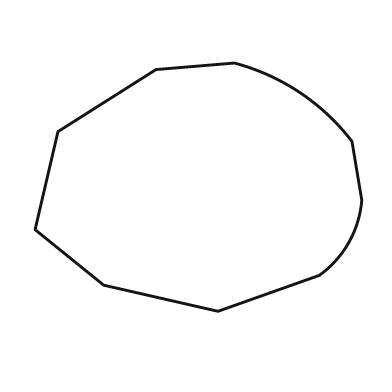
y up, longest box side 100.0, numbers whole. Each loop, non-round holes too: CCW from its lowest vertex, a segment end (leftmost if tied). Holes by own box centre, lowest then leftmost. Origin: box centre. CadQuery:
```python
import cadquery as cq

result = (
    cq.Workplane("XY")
    .moveTo(6.0, -38.0)
    .lineTo(37.0, -27.0)
    .threePointArc((46.0, -17.0), (50.0, -4.0))
    .lineTo(47.0, 14.0)
    .threePointArc((31.0, 29.0), (11.0, 38.0))
    .lineTo(-13.0, 36.0)
    .lineTo(-43.0, 17.0)
    .lineTo(-50.0, -13.0)
    .lineTo(-29.0, -30.0)
    .close()
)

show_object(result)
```